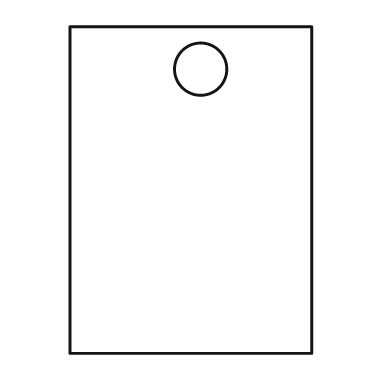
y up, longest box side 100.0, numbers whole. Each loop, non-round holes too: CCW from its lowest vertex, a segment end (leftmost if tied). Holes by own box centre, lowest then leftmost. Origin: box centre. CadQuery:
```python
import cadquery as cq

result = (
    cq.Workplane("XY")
    .moveTo(-37.0, -50.0)
    .lineTo(37.0, -50.0)
    .lineTo(37.0, 50.0)
    .lineTo(-37.0, 50.0)
    .close()
    .moveTo(3.0, 37.0)
    .circle(8.0)
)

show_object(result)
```